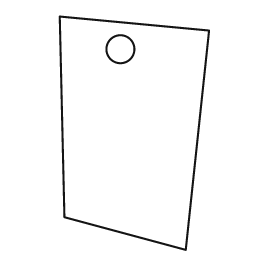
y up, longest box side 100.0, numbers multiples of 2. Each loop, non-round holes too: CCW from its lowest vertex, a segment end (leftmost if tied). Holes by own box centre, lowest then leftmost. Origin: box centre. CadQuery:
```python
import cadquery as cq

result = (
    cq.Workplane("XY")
    .moveTo(22.0, -50.0)
    .lineTo(32.0, 44.0)
    .lineTo(-32.0, 50.0)
    .lineTo(-30.0, -36.0)
    .close()
    .moveTo(-6.0, 36.0)
    .circle(6.0)
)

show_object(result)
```